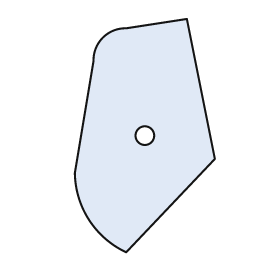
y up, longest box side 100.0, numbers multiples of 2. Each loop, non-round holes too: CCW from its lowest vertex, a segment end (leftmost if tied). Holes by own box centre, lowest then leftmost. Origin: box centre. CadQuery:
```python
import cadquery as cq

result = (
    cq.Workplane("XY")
    .moveTo(-8.0, -50.0)
    .lineTo(30.0, -10.0)
    .lineTo(18.0, 50.0)
    .lineTo(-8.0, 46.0)
    .threePointArc((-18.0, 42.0), (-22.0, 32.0))
    .lineTo(-30.0, -16.0)
    .threePointArc((-24.0, -36.0), (-8.0, -50.0))
    .close()
    .moveTo(0.0, 0.0)
    .circle(4.0)
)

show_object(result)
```